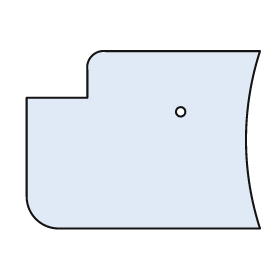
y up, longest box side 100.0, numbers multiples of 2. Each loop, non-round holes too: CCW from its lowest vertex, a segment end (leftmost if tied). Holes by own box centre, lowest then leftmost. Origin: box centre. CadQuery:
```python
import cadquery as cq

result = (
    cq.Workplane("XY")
    .moveTo(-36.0, -38.0)
    .lineTo(50.0, -38.0)
    .threePointArc((44.0, 0.0), (50.0, 38.0))
    .lineTo(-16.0, 38.0)
    .threePointArc((-22.0, 36.0), (-24.0, 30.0))
    .lineTo(-24.0, 18.0)
    .lineTo(-50.0, 18.0)
    .lineTo(-50.0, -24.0)
    .threePointArc((-46.0, -34.0), (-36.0, -38.0))
    .close()
    .moveTo(16.0, 12.0)
    .circle(2.0)
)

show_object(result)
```